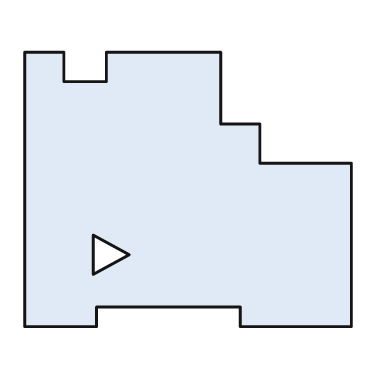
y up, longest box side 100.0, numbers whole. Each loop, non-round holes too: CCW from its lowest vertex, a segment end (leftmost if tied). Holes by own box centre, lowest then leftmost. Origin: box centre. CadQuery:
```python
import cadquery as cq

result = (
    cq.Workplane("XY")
    .moveTo(-50.0, -42.0)
    .lineTo(-28.0, -42.0)
    .lineTo(-28.0, -36.0)
    .lineTo(16.0, -36.0)
    .lineTo(16.0, -42.0)
    .lineTo(50.0, -42.0)
    .lineTo(50.0, 8.0)
    .lineTo(22.0, 8.0)
    .lineTo(22.0, 20.0)
    .lineTo(10.0, 20.0)
    .lineTo(10.0, 42.0)
    .lineTo(-25.0, 42.0)
    .lineTo(-25.0, 33.0)
    .lineTo(-38.0, 33.0)
    .lineTo(-38.0, 42.0)
    .lineTo(-50.0, 42.0)
    .close()
    .moveTo(-29.0, -26.0)
    .lineTo(-18.0, -20.0)
    .lineTo(-29.0, -14.0)
    .close()
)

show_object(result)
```